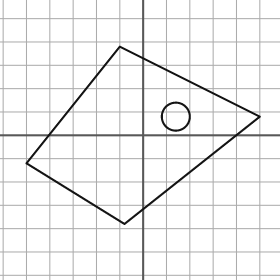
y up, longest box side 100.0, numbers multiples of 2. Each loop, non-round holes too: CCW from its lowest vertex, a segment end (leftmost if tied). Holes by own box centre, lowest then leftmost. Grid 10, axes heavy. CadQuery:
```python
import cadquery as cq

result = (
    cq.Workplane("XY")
    .moveTo(-8.0, -38.0)
    .lineTo(50.0, 8.0)
    .lineTo(-10.0, 38.0)
    .lineTo(-50.0, -12.0)
    .close()
    .moveTo(14.0, 8.0)
    .circle(6.0)
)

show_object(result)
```